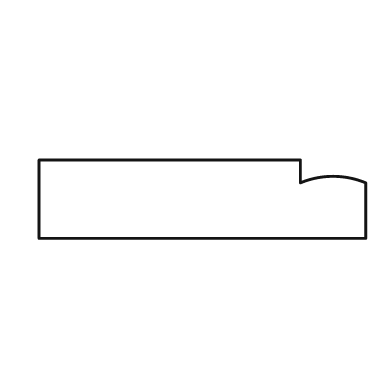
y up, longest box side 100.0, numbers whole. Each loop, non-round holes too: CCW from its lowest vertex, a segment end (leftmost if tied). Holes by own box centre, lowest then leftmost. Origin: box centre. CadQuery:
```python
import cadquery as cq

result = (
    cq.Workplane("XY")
    .moveTo(-50.0, -12.0)
    .lineTo(50.0, -12.0)
    .lineTo(50.0, 5.0)
    .threePointArc((40.0, 7.0), (30.0, 5.0))
    .lineTo(30.0, 12.0)
    .lineTo(-50.0, 12.0)
    .close()
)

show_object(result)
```